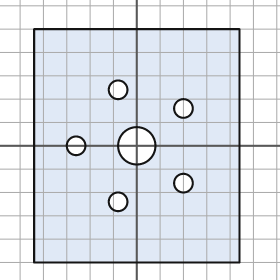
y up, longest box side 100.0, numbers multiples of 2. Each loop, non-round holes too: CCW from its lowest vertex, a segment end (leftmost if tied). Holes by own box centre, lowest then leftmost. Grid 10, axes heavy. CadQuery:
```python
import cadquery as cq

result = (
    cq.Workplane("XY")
    .moveTo(-44.0, -50.0)
    .lineTo(44.0, -50.0)
    .lineTo(44.0, 50.0)
    .lineTo(-44.0, 50.0)
    .close()
    .moveTo(-8.0, -24.0)
    .circle(4.0)
    .moveTo(20.0, -16.0)
    .circle(4.0)
    .moveTo(-26.0, 0.0)
    .circle(4.0)
    .moveTo(0.0, 0.0)
    .circle(8.0)
    .moveTo(20.0, 16.0)
    .circle(4.0)
    .moveTo(-8.0, 24.0)
    .circle(4.0)
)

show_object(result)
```